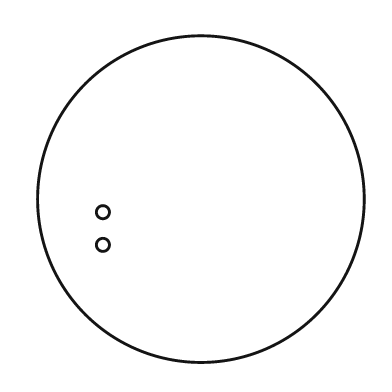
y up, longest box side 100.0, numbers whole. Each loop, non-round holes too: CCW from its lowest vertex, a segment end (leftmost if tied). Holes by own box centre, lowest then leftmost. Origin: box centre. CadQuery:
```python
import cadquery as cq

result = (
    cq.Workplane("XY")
    .moveTo(0.0, 0.0)
    .circle(50.0)
    .moveTo(-30.0, -14.0)
    .circle(2.0)
    .moveTo(-30.0, -4.0)
    .circle(2.0)
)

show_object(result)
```